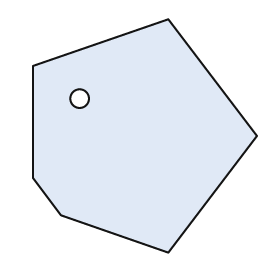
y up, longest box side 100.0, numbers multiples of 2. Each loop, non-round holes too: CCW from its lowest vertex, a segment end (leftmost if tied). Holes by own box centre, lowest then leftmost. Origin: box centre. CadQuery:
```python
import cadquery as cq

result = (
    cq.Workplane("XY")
    .moveTo(10.0, -50.0)
    .lineTo(48.0, 0.0)
    .lineTo(10.0, 50.0)
    .lineTo(-48.0, 30.0)
    .lineTo(-48.0, -18.0)
    .lineTo(-36.0, -34.0)
    .close()
    .moveTo(-28.0, 16.0)
    .circle(4.0)
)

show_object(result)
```